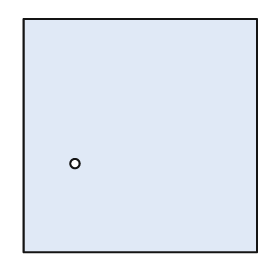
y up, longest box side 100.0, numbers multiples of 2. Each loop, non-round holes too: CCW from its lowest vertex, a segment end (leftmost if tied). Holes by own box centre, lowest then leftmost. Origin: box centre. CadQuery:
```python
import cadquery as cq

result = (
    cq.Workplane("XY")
    .moveTo(-50.0, -50.0)
    .lineTo(50.0, -50.0)
    .lineTo(50.0, 50.0)
    .lineTo(-50.0, 50.0)
    .close()
    .moveTo(-28.0, -12.0)
    .circle(2.0)
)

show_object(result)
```